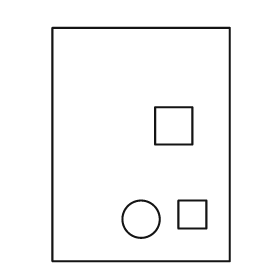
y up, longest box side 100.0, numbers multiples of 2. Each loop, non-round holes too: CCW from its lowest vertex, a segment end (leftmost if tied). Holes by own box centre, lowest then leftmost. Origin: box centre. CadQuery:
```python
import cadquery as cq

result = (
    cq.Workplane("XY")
    .moveTo(-38.0, -50.0)
    .lineTo(38.0, -50.0)
    .lineTo(38.0, 50.0)
    .lineTo(-38.0, 50.0)
    .close()
    .moveTo(0.0, -32.0)
    .circle(8.0)
    .moveTo(16.0, -36.0)
    .lineTo(28.0, -36.0)
    .lineTo(28.0, -24.0)
    .lineTo(16.0, -24.0)
    .close()
    .moveTo(6.0, 0.0)
    .lineTo(22.0, 0.0)
    .lineTo(22.0, 16.0)
    .lineTo(6.0, 16.0)
    .close()
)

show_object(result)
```